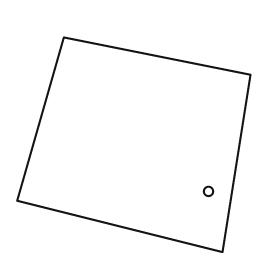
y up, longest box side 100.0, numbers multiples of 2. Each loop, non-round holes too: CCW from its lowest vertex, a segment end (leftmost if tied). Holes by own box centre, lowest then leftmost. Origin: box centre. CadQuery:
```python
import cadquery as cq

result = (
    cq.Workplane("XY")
    .moveTo(38.0, -46.0)
    .lineTo(50.0, 30.0)
    .lineTo(-30.0, 46.0)
    .lineTo(-50.0, -24.0)
    .close()
    .moveTo(32.0, -20.0)
    .circle(2.0)
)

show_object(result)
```